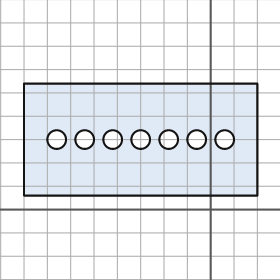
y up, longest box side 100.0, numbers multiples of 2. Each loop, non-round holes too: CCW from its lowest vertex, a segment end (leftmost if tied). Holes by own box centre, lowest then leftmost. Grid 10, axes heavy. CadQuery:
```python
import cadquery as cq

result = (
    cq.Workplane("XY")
    .moveTo(-80.0, 6.0)
    .lineTo(20.0, 6.0)
    .lineTo(20.0, 54.0)
    .lineTo(-80.0, 54.0)
    .close()
    .moveTo(-66.0, 30.0)
    .circle(4.0)
    .moveTo(-54.0, 30.0)
    .circle(4.0)
    .moveTo(-42.0, 30.0)
    .circle(4.0)
    .moveTo(-30.0, 30.0)
    .circle(4.0)
    .moveTo(-18.0, 30.0)
    .circle(4.0)
    .moveTo(-6.0, 30.0)
    .circle(4.0)
    .moveTo(6.0, 30.0)
    .circle(4.0)
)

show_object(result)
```